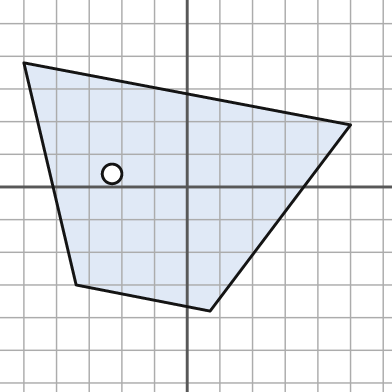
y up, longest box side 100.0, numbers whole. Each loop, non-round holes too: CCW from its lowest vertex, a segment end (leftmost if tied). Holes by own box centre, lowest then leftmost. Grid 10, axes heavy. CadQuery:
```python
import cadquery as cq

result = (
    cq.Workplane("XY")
    .moveTo(7.0, -38.0)
    .lineTo(50.0, 19.0)
    .lineTo(-50.0, 38.0)
    .lineTo(-34.0, -30.0)
    .close()
    .moveTo(-23.0, 4.0)
    .circle(3.0)
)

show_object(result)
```